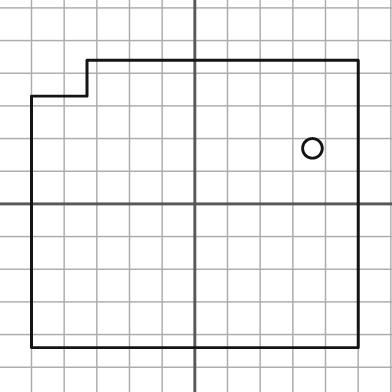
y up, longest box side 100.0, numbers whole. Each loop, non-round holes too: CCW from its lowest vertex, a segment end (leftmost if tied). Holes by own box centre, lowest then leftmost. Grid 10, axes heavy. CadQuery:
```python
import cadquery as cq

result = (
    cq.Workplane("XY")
    .moveTo(-50.0, -44.0)
    .lineTo(50.0, -44.0)
    .lineTo(50.0, 44.0)
    .lineTo(-33.0, 44.0)
    .lineTo(-33.0, 33.0)
    .lineTo(-50.0, 33.0)
    .close()
    .moveTo(36.0, 17.0)
    .circle(3.0)
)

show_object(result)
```